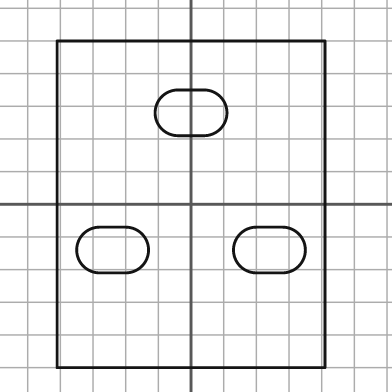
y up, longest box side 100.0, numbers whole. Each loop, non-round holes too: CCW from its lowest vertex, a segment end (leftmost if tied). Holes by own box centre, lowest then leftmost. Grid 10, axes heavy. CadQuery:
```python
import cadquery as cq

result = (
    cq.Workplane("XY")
    .moveTo(-41.0, -50.0)
    .lineTo(41.0, -50.0)
    .lineTo(41.0, 50.0)
    .lineTo(-41.0, 50.0)
    .close()
    .moveTo(-28.0, -21.0)
    .lineTo(-20.0, -21.0)
    .threePointArc((-13.0, -14.0), (-20.0, -7.0))
    .lineTo(-28.0, -7.0)
    .threePointArc((-35.0, -14.0), (-28.0, -21.0))
    .close()
    .moveTo(20.0, -21.0)
    .lineTo(28.0, -21.0)
    .threePointArc((35.0, -14.0), (28.0, -7.0))
    .lineTo(20.0, -7.0)
    .threePointArc((13.0, -14.0), (20.0, -21.0))
    .close()
    .moveTo(-4.0, 21.0)
    .lineTo(4.0, 21.0)
    .threePointArc((11.0, 28.0), (4.0, 35.0))
    .lineTo(-4.0, 35.0)
    .threePointArc((-11.0, 28.0), (-4.0, 21.0))
    .close()
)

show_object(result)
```